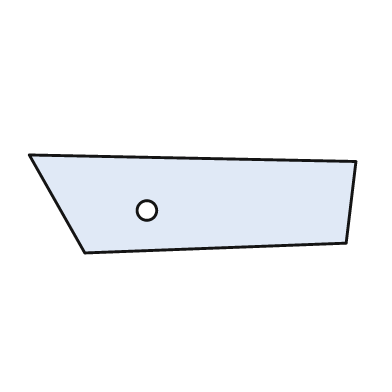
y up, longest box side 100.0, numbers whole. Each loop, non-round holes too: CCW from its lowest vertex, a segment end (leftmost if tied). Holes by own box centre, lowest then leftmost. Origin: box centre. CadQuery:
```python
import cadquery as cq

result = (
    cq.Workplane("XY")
    .moveTo(-33.0, -15.0)
    .lineTo(47.0, -12.0)
    .lineTo(50.0, 13.0)
    .lineTo(-50.0, 15.0)
    .close()
    .moveTo(-14.0, -2.0)
    .circle(3.0)
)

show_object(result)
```